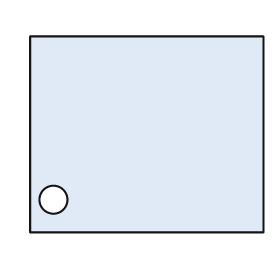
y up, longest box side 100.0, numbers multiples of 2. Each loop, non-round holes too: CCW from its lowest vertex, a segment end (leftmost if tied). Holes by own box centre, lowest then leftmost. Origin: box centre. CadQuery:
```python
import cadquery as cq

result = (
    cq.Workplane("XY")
    .moveTo(-50.0, -42.0)
    .lineTo(50.0, -42.0)
    .lineTo(50.0, 42.0)
    .lineTo(-50.0, 42.0)
    .close()
    .moveTo(-40.0, -28.0)
    .circle(6.0)
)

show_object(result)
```